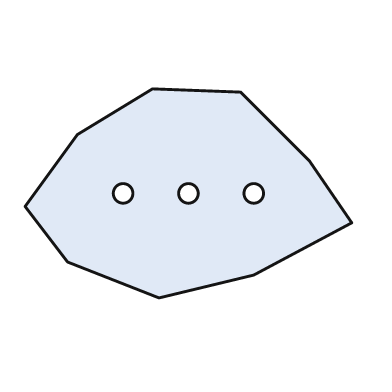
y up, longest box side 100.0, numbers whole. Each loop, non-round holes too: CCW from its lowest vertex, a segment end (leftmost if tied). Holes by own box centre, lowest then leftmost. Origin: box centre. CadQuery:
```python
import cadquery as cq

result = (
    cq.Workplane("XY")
    .moveTo(-9.0, -32.0)
    .lineTo(20.0, -25.0)
    .lineTo(50.0, -9.0)
    .lineTo(37.0, 10.0)
    .lineTo(16.0, 31.0)
    .lineTo(-11.0, 32.0)
    .lineTo(-34.0, 18.0)
    .lineTo(-50.0, -4.0)
    .lineTo(-37.0, -21.0)
    .close()
    .moveTo(-20.0, 0.0)
    .circle(3.0)
    .moveTo(0.0, 0.0)
    .circle(3.0)
    .moveTo(20.0, 0.0)
    .circle(3.0)
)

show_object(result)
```